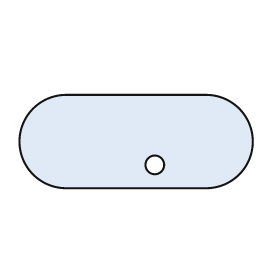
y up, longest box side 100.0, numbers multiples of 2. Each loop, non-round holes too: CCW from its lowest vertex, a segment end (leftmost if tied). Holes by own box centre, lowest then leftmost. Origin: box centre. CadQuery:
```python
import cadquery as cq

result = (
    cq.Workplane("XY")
    .moveTo(-30.0, -20.0)
    .lineTo(30.0, -20.0)
    .threePointArc((50.0, 0.0), (30.0, 20.0))
    .lineTo(-30.0, 20.0)
    .threePointArc((-50.0, 0.0), (-30.0, -20.0))
    .close()
    .moveTo(8.0, -10.0)
    .circle(4.0)
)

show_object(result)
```